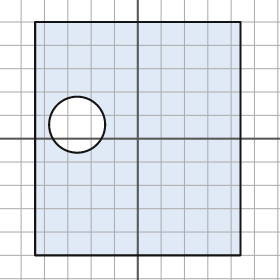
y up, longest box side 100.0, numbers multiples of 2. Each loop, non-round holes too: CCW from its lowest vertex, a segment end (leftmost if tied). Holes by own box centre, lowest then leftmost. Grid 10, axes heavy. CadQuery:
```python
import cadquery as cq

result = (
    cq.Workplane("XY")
    .moveTo(-44.0, -50.0)
    .lineTo(44.0, -50.0)
    .lineTo(44.0, 50.0)
    .lineTo(-44.0, 50.0)
    .close()
    .moveTo(-26.0, 6.0)
    .circle(12.0)
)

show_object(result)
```